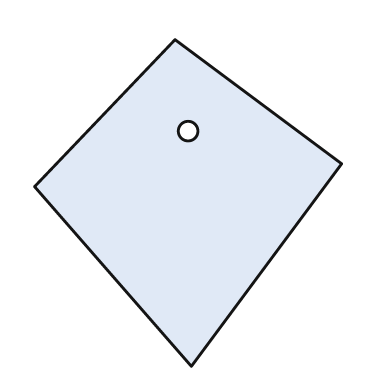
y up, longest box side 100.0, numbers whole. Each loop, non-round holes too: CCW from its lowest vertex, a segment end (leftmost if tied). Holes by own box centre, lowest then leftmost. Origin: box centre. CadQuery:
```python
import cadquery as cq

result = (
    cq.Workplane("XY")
    .moveTo(1.0, -50.0)
    .lineTo(47.0, 12.0)
    .lineTo(-4.0, 50.0)
    .lineTo(-47.0, 5.0)
    .close()
    .moveTo(0.0, 22.0)
    .circle(3.0)
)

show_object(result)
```